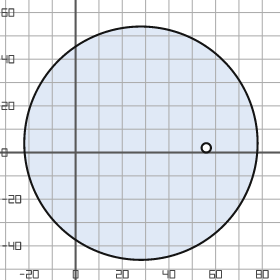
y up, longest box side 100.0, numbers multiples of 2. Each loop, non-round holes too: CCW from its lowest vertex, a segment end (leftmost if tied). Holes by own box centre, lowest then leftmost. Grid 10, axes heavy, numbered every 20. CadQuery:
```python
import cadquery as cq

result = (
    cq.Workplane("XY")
    .moveTo(28.0, 4.0)
    .circle(50.0)
    .moveTo(56.0, 2.0)
    .circle(2.0)
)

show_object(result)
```